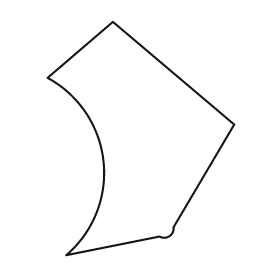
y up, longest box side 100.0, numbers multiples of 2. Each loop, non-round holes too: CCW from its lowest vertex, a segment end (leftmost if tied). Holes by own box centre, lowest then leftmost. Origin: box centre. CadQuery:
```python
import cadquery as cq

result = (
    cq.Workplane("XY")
    .moveTo(-32.0, -50.0)
    .lineTo(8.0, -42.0)
    .threePointArc((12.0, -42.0), (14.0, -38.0))
    .lineTo(40.0, 6.0)
    .lineTo(-12.0, 50.0)
    .lineTo(-40.0, 26.0)
    .threePointArc((-16.0, -10.0), (-32.0, -50.0))
    .close()
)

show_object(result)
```